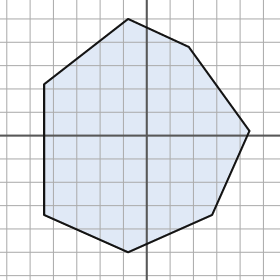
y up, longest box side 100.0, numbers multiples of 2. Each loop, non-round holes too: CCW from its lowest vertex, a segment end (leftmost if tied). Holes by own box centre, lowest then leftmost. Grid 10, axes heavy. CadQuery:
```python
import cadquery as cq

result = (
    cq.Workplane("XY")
    .moveTo(-8.0, -50.0)
    .lineTo(28.0, -34.0)
    .lineTo(44.0, 2.0)
    .lineTo(18.0, 38.0)
    .lineTo(-8.0, 50.0)
    .lineTo(-44.0, 22.0)
    .lineTo(-44.0, -34.0)
    .close()
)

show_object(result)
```